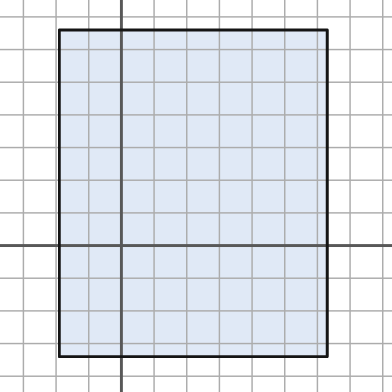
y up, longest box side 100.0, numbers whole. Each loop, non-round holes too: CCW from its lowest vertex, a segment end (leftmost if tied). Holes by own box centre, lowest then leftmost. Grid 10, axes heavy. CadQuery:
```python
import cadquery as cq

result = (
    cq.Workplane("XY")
    .moveTo(-19.0, -34.0)
    .lineTo(63.0, -34.0)
    .lineTo(63.0, 66.0)
    .lineTo(-19.0, 66.0)
    .close()
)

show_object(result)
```